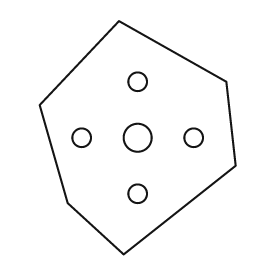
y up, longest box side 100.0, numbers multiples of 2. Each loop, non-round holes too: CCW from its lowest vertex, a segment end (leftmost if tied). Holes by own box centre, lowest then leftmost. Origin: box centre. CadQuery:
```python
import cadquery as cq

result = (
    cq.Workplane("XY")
    .moveTo(-6.0, -50.0)
    .lineTo(42.0, -12.0)
    .lineTo(38.0, 24.0)
    .lineTo(-8.0, 50.0)
    .lineTo(-42.0, 14.0)
    .lineTo(-30.0, -28.0)
    .close()
    .moveTo(0.0, -24.0)
    .circle(4.0)
    .moveTo(-24.0, 0.0)
    .circle(4.0)
    .moveTo(0.0, 0.0)
    .circle(6.0)
    .moveTo(24.0, 0.0)
    .circle(4.0)
    .moveTo(0.0, 24.0)
    .circle(4.0)
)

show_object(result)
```